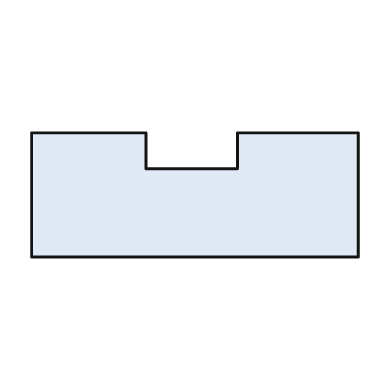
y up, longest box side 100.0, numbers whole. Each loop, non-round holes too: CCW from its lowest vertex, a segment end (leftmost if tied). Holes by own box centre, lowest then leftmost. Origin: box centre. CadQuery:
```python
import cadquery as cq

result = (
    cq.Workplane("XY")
    .moveTo(-50.0, -19.0)
    .lineTo(50.0, -19.0)
    .lineTo(50.0, 19.0)
    .lineTo(13.0, 19.0)
    .lineTo(13.0, 8.0)
    .lineTo(-15.0, 8.0)
    .lineTo(-15.0, 19.0)
    .lineTo(-50.0, 19.0)
    .close()
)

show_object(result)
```